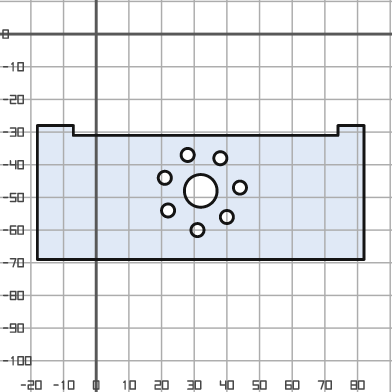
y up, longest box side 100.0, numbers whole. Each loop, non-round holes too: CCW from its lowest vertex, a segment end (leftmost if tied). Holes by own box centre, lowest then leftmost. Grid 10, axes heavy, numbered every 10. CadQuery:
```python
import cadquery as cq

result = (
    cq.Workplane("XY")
    .moveTo(-18.0, -69.0)
    .lineTo(82.0, -69.0)
    .lineTo(82.0, -28.0)
    .lineTo(74.0, -28.0)
    .lineTo(74.0, -31.0)
    .lineTo(-7.0, -31.0)
    .lineTo(-7.0, -28.0)
    .lineTo(-18.0, -28.0)
    .close()
    .moveTo(31.0, -60.0)
    .circle(2.0)
    .moveTo(40.0, -56.0)
    .circle(2.0)
    .moveTo(22.0, -54.0)
    .circle(2.0)
    .moveTo(32.0, -48.0)
    .circle(5.0)
    .moveTo(44.0, -47.0)
    .circle(2.0)
    .moveTo(21.0, -44.0)
    .circle(2.0)
    .moveTo(38.0, -38.0)
    .circle(2.0)
    .moveTo(28.0, -37.0)
    .circle(2.0)
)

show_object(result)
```